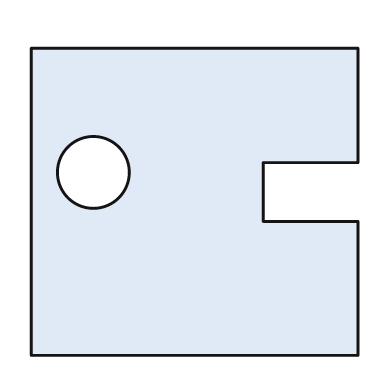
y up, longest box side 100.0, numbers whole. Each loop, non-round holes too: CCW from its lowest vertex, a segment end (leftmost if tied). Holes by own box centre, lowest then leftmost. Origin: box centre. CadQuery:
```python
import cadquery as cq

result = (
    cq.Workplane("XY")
    .moveTo(-50.0, -47.0)
    .lineTo(50.0, -47.0)
    .lineTo(50.0, -6.0)
    .lineTo(21.0, -6.0)
    .lineTo(21.0, 12.0)
    .lineTo(50.0, 12.0)
    .lineTo(50.0, 47.0)
    .lineTo(-50.0, 47.0)
    .close()
    .moveTo(-31.0, 9.0)
    .circle(11.0)
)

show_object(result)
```